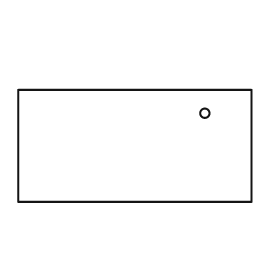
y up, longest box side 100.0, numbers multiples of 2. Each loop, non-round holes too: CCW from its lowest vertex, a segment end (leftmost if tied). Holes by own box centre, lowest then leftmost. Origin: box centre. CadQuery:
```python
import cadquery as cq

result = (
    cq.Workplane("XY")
    .moveTo(-50.0, -24.0)
    .lineTo(50.0, -24.0)
    .lineTo(50.0, 24.0)
    .lineTo(-50.0, 24.0)
    .close()
    .moveTo(30.0, 14.0)
    .circle(2.0)
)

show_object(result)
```